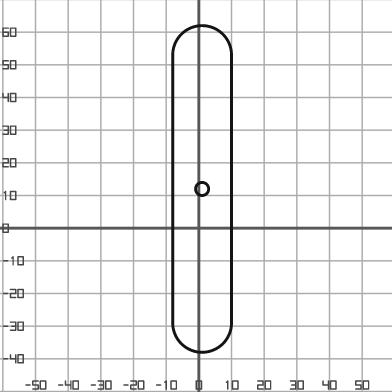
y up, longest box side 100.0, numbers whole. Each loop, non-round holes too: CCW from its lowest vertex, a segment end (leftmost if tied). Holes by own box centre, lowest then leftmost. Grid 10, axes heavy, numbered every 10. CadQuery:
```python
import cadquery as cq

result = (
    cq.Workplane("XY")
    .moveTo(-8.0, -29.0)
    .threePointArc((1.0, -38.0), (10.0, -29.0))
    .lineTo(10.0, 53.0)
    .threePointArc((1.0, 62.0), (-8.0, 53.0))
    .close()
    .moveTo(1.0, 12.0)
    .circle(2.0)
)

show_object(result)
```